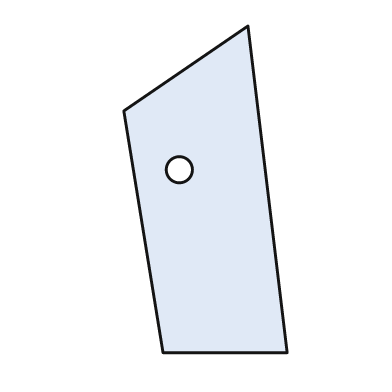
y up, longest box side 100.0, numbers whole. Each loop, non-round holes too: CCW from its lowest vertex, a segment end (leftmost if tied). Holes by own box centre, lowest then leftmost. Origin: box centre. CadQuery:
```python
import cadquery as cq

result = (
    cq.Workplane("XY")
    .moveTo(-13.0, -50.0)
    .lineTo(25.0, -50.0)
    .lineTo(13.0, 50.0)
    .lineTo(-25.0, 24.0)
    .close()
    .moveTo(-8.0, 6.0)
    .circle(4.0)
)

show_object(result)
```